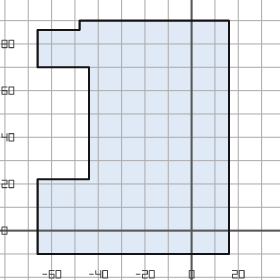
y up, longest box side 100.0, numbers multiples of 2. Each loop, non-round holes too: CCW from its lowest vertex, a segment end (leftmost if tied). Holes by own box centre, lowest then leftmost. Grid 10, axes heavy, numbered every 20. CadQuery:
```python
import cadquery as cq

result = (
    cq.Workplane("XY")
    .moveTo(-66.0, -10.0)
    .lineTo(16.0, -10.0)
    .lineTo(16.0, 90.0)
    .lineTo(-48.0, 90.0)
    .lineTo(-48.0, 86.0)
    .lineTo(-66.0, 86.0)
    .lineTo(-66.0, 70.0)
    .lineTo(-44.0, 70.0)
    .lineTo(-44.0, 22.0)
    .lineTo(-66.0, 22.0)
    .close()
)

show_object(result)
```